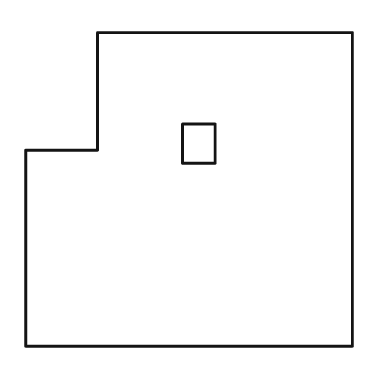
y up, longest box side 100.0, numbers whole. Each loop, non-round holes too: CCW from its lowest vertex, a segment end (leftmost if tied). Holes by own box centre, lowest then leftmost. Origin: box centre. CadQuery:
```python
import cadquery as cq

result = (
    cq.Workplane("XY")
    .moveTo(-50.0, -48.0)
    .lineTo(50.0, -48.0)
    .lineTo(50.0, 48.0)
    .lineTo(-28.0, 48.0)
    .lineTo(-28.0, 12.0)
    .lineTo(-50.0, 12.0)
    .close()
    .moveTo(-2.0, 8.0)
    .lineTo(8.0, 8.0)
    .lineTo(8.0, 20.0)
    .lineTo(-2.0, 20.0)
    .close()
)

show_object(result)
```